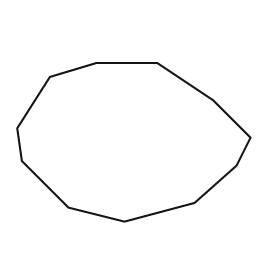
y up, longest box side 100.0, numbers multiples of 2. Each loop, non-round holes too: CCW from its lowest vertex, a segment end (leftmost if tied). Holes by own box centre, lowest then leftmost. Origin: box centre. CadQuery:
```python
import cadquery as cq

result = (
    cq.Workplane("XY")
    .moveTo(-4.0, -34.0)
    .lineTo(26.0, -26.0)
    .lineTo(44.0, -10.0)
    .lineTo(50.0, 2.0)
    .lineTo(34.0, 18.0)
    .lineTo(10.0, 34.0)
    .lineTo(-16.0, 34.0)
    .lineTo(-36.0, 28.0)
    .lineTo(-50.0, 6.0)
    .lineTo(-48.0, -8.0)
    .lineTo(-28.0, -28.0)
    .close()
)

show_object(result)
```